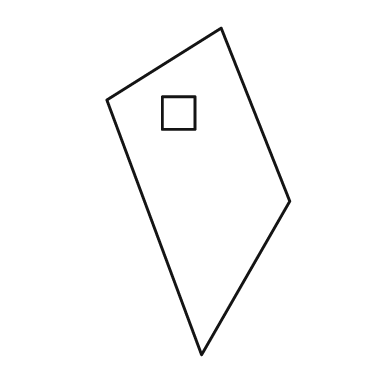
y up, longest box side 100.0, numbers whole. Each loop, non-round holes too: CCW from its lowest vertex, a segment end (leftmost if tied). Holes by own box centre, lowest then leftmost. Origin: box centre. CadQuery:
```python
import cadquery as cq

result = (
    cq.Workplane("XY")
    .moveTo(1.0, -50.0)
    .lineTo(28.0, -3.0)
    .lineTo(7.0, 50.0)
    .lineTo(-28.0, 28.0)
    .close()
    .moveTo(-11.0, 19.0)
    .lineTo(-1.0, 19.0)
    .lineTo(-1.0, 29.0)
    .lineTo(-11.0, 29.0)
    .close()
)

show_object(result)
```